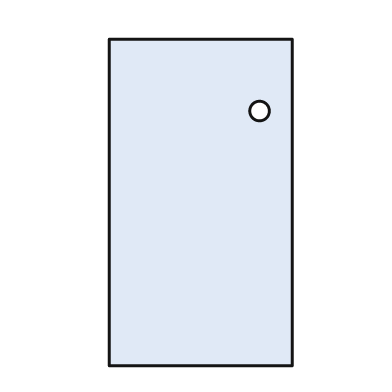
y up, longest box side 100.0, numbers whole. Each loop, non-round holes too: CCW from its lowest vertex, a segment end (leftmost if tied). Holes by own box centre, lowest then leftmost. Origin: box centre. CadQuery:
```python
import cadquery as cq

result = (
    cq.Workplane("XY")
    .moveTo(-28.0, -50.0)
    .lineTo(28.0, -50.0)
    .lineTo(28.0, 50.0)
    .lineTo(-28.0, 50.0)
    .close()
    .moveTo(18.0, 28.0)
    .circle(3.0)
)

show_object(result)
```